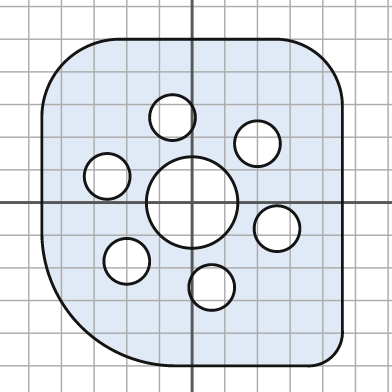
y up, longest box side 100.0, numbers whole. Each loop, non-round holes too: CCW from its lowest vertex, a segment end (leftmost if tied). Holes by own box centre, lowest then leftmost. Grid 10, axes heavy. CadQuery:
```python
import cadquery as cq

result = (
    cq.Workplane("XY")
    .moveTo(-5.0, -50.0)
    .lineTo(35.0, -50.0)
    .threePointArc((43.0, -47.0), (46.0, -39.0))
    .lineTo(46.0, 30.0)
    .threePointArc((40.0, 44.0), (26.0, 50.0))
    .lineTo(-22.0, 50.0)
    .threePointArc((-39.0, 43.0), (-46.0, 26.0))
    .lineTo(-46.0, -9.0)
    .threePointArc((-34.0, -38.0), (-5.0, -50.0))
    .close()
    .moveTo(6.0, -26.0)
    .circle(7.0)
    .moveTo(-20.0, -18.0)
    .circle(7.0)
    .moveTo(26.0, -8.0)
    .circle(7.0)
    .moveTo(0.0, 0.0)
    .circle(14.0)
    .moveTo(-26.0, 8.0)
    .circle(7.0)
    .moveTo(20.0, 18.0)
    .circle(7.0)
    .moveTo(-6.0, 26.0)
    .circle(7.0)
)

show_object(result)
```